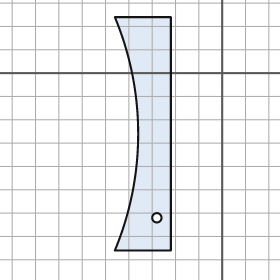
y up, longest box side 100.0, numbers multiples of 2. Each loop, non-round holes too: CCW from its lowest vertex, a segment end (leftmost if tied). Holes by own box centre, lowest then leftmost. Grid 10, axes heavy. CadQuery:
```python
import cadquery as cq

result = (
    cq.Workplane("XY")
    .moveTo(-46.0, -76.0)
    .lineTo(-22.0, -76.0)
    .lineTo(-22.0, 24.0)
    .lineTo(-46.0, 24.0)
    .threePointArc((-36.0, -26.0), (-46.0, -76.0))
    .close()
    .moveTo(-28.0, -62.0)
    .circle(2.0)
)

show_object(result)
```